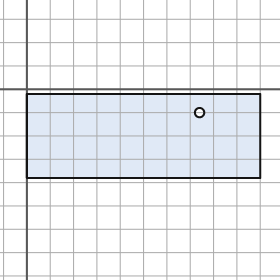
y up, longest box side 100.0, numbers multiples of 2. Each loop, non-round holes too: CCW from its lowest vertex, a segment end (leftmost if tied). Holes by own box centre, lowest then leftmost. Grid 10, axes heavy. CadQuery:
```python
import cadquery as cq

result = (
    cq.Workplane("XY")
    .moveTo(0.0, -38.0)
    .lineTo(100.0, -38.0)
    .lineTo(100.0, -2.0)
    .lineTo(0.0, -2.0)
    .close()
    .moveTo(74.0, -10.0)
    .circle(2.0)
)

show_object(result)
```